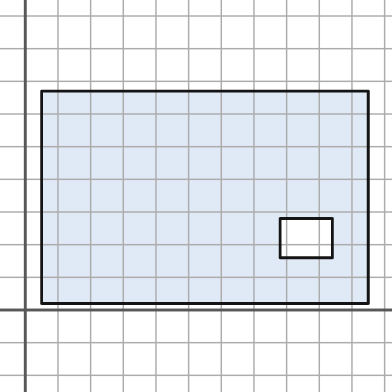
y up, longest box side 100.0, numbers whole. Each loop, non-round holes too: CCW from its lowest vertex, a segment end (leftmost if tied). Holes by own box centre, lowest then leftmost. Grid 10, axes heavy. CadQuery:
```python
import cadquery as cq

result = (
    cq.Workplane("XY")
    .moveTo(5.0, 2.0)
    .lineTo(105.0, 2.0)
    .lineTo(105.0, 67.0)
    .lineTo(5.0, 67.0)
    .close()
    .moveTo(78.0, 16.0)
    .lineTo(94.0, 16.0)
    .lineTo(94.0, 28.0)
    .lineTo(78.0, 28.0)
    .close()
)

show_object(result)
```